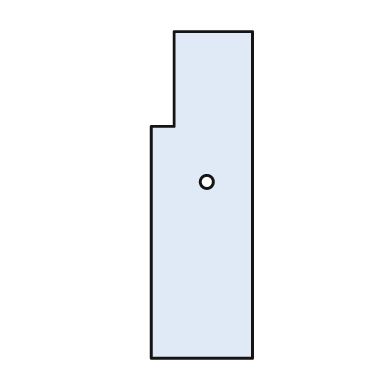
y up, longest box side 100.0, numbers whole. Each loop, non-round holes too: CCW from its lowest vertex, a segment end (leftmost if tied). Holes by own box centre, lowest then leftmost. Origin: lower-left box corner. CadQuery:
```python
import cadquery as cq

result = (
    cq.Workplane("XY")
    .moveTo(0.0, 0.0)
    .lineTo(31.0, 0.0)
    .lineTo(31.0, 100.0)
    .lineTo(7.0, 100.0)
    .lineTo(7.0, 71.0)
    .lineTo(0.0, 71.0)
    .close()
    .moveTo(17.0, 54.0)
    .circle(2.0)
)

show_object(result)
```